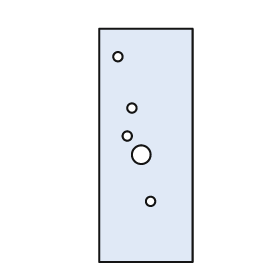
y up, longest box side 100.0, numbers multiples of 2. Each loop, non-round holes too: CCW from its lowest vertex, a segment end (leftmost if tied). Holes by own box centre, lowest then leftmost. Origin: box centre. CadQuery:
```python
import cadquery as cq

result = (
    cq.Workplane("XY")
    .moveTo(-20.0, -50.0)
    .lineTo(20.0, -50.0)
    .lineTo(20.0, 50.0)
    .lineTo(-20.0, 50.0)
    .close()
    .moveTo(2.0, -24.0)
    .circle(2.0)
    .moveTo(-2.0, -4.0)
    .circle(4.0)
    .moveTo(-8.0, 4.0)
    .circle(2.0)
    .moveTo(-6.0, 16.0)
    .circle(2.0)
    .moveTo(-12.0, 38.0)
    .circle(2.0)
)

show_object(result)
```